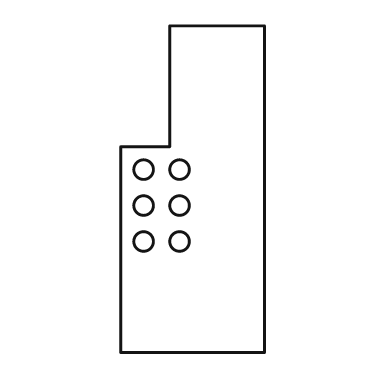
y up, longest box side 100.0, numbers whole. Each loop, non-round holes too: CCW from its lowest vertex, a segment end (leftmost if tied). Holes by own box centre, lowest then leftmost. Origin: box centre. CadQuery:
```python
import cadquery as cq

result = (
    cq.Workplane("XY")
    .moveTo(-22.0, -50.0)
    .lineTo(22.0, -50.0)
    .lineTo(22.0, 50.0)
    .lineTo(-7.0, 50.0)
    .lineTo(-7.0, 13.0)
    .lineTo(-22.0, 13.0)
    .close()
    .moveTo(-15.0, -16.0)
    .circle(3.0)
    .moveTo(-4.0, -16.0)
    .circle(3.0)
    .moveTo(-15.0, -5.0)
    .circle(3.0)
    .moveTo(-4.0, -5.0)
    .circle(3.0)
    .moveTo(-15.0, 6.0)
    .circle(3.0)
    .moveTo(-4.0, 6.0)
    .circle(3.0)
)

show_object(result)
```